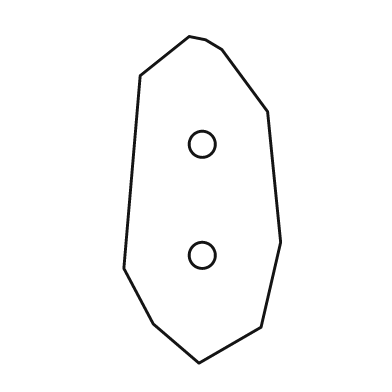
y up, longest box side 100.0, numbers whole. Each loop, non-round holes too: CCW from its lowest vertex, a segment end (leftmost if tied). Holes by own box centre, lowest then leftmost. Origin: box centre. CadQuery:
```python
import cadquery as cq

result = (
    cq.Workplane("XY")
    .moveTo(-1.0, -50.0)
    .lineTo(18.0, -39.0)
    .lineTo(24.0, -13.0)
    .lineTo(20.0, 27.0)
    .lineTo(6.0, 46.0)
    .lineTo(1.0, 49.0)
    .lineTo(-4.0, 50.0)
    .lineTo(-19.0, 38.0)
    .lineTo(-24.0, -21.0)
    .lineTo(-15.0, -38.0)
    .close()
    .moveTo(0.0, -17.0)
    .circle(4.0)
    .moveTo(0.0, 17.0)
    .circle(4.0)
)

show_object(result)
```